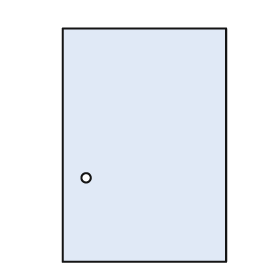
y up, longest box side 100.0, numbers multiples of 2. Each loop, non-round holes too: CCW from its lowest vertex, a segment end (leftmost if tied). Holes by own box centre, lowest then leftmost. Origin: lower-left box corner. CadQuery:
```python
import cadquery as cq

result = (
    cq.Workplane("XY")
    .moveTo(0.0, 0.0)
    .lineTo(70.0, 0.0)
    .lineTo(70.0, 100.0)
    .lineTo(0.0, 100.0)
    .close()
    .moveTo(10.0, 36.0)
    .circle(2.0)
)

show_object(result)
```